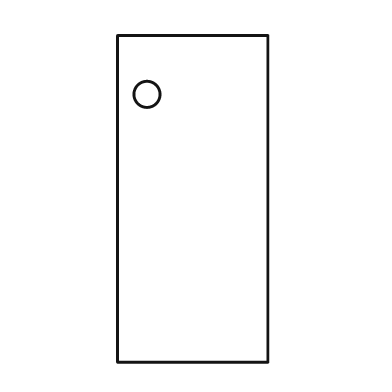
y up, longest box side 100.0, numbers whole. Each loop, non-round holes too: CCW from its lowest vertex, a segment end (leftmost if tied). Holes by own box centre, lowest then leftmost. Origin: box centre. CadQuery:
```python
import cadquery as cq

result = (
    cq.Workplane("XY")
    .moveTo(-23.0, -50.0)
    .lineTo(23.0, -50.0)
    .lineTo(23.0, 50.0)
    .lineTo(-23.0, 50.0)
    .close()
    .moveTo(-14.0, 32.0)
    .circle(4.0)
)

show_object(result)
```